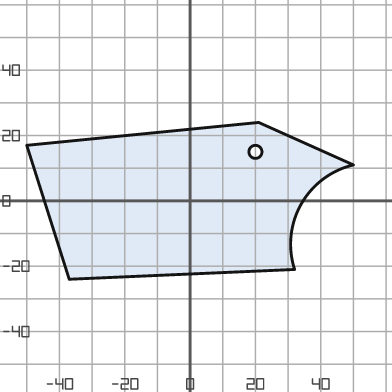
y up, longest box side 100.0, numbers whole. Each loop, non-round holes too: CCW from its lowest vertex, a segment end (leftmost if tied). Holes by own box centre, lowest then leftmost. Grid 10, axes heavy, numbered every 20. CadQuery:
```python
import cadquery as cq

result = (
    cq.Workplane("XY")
    .moveTo(-37.0, -24.0)
    .lineTo(32.0, -21.0)
    .threePointArc((34.0, -1.0), (50.0, 11.0))
    .lineTo(21.0, 24.0)
    .lineTo(-50.0, 17.0)
    .close()
    .moveTo(20.0, 15.0)
    .circle(2.0)
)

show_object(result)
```